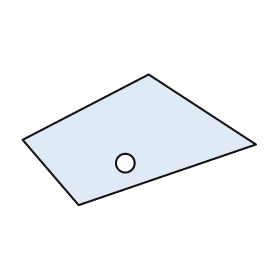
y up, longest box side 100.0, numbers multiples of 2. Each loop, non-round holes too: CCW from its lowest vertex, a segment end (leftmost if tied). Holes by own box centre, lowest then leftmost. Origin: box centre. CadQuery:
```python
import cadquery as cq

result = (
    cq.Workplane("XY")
    .moveTo(-26.0, -28.0)
    .lineTo(50.0, -2.0)
    .lineTo(4.0, 28.0)
    .lineTo(-50.0, 0.0)
    .close()
    .moveTo(-6.0, -10.0)
    .circle(4.0)
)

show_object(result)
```